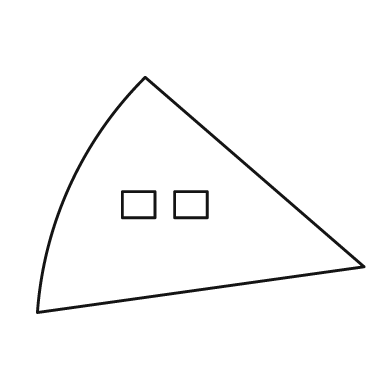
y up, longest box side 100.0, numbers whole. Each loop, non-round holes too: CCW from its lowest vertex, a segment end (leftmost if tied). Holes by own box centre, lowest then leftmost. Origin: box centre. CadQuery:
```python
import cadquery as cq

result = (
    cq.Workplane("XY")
    .moveTo(-50.0, -36.0)
    .lineTo(50.0, -22.0)
    .lineTo(-17.0, 36.0)
    .threePointArc((-40.0, 3.0), (-50.0, -36.0))
    .close()
    .moveTo(-24.0, -7.0)
    .lineTo(-14.0, -7.0)
    .lineTo(-14.0, 1.0)
    .lineTo(-24.0, 1.0)
    .close()
    .moveTo(-8.0, -7.0)
    .lineTo(2.0, -7.0)
    .lineTo(2.0, 1.0)
    .lineTo(-8.0, 1.0)
    .close()
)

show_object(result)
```